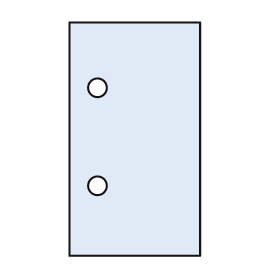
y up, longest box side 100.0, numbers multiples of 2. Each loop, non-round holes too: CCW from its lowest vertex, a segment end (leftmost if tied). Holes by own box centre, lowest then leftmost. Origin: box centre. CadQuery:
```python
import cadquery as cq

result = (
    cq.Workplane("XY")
    .moveTo(-28.0, -50.0)
    .lineTo(28.0, -50.0)
    .lineTo(28.0, 50.0)
    .lineTo(-28.0, 50.0)
    .close()
    .moveTo(-16.0, -20.0)
    .circle(4.0)
    .moveTo(-16.0, 22.0)
    .circle(4.0)
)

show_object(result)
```